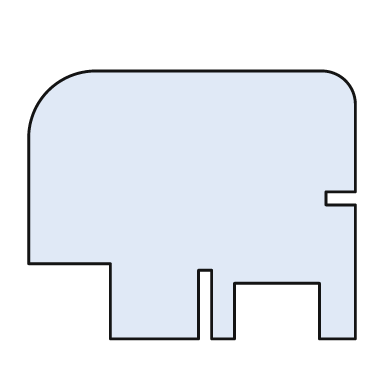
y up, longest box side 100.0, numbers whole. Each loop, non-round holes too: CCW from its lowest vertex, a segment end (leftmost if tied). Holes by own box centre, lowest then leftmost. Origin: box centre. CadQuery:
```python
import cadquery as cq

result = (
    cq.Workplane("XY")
    .moveTo(-25.0, -41.0)
    .lineTo(2.0, -41.0)
    .lineTo(2.0, -20.0)
    .lineTo(6.0, -20.0)
    .lineTo(6.0, -41.0)
    .lineTo(13.0, -41.0)
    .lineTo(13.0, -24.0)
    .lineTo(39.0, -24.0)
    .lineTo(39.0, -41.0)
    .lineTo(50.0, -41.0)
    .lineTo(50.0, 0.0)
    .lineTo(41.0, 0.0)
    .lineTo(41.0, 4.0)
    .lineTo(50.0, 4.0)
    .lineTo(50.0, 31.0)
    .threePointArc((47.0, 38.0), (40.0, 41.0))
    .lineTo(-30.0, 41.0)
    .threePointArc((-44.0, 35.0), (-50.0, 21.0))
    .lineTo(-50.0, -18.0)
    .lineTo(-25.0, -18.0)
    .close()
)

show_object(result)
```